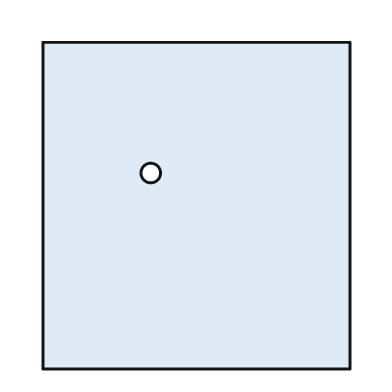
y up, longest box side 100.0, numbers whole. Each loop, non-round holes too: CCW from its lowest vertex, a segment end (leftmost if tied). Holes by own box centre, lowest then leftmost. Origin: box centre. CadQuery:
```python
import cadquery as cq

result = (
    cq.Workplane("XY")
    .moveTo(-47.0, -50.0)
    .lineTo(47.0, -50.0)
    .lineTo(47.0, 50.0)
    .lineTo(-47.0, 50.0)
    .close()
    .moveTo(-14.0, 10.0)
    .circle(3.0)
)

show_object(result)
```